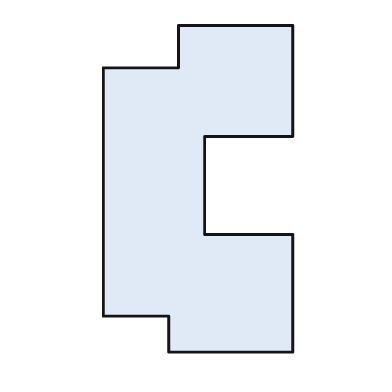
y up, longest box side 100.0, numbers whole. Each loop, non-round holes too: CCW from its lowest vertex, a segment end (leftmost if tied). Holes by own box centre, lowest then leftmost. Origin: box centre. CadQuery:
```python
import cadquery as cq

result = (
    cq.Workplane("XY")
    .moveTo(-9.0, -50.0)
    .lineTo(29.0, -50.0)
    .lineTo(29.0, -14.0)
    .lineTo(2.0, -14.0)
    .lineTo(2.0, 16.0)
    .lineTo(29.0, 16.0)
    .lineTo(29.0, 50.0)
    .lineTo(-6.0, 50.0)
    .lineTo(-6.0, 37.0)
    .lineTo(-29.0, 37.0)
    .lineTo(-29.0, -39.0)
    .lineTo(-9.0, -39.0)
    .close()
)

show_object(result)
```